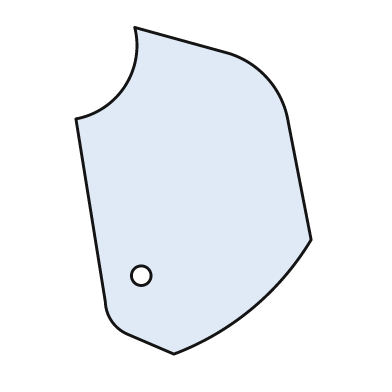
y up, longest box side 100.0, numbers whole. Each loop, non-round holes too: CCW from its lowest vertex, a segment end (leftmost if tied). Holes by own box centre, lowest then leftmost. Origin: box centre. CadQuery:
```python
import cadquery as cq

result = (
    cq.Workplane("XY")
    .moveTo(-6.0, -50.0)
    .threePointArc((18.0, -36.0), (36.0, -15.0))
    .lineTo(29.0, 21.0)
    .threePointArc((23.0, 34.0), (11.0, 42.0))
    .lineTo(-18.0, 50.0)
    .threePointArc((-21.0, 32.0), (-36.0, 22.0))
    .lineTo(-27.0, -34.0)
    .threePointArc((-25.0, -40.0), (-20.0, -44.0))
    .close()
    .moveTo(-16.0, -26.0)
    .circle(3.0)
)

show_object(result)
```